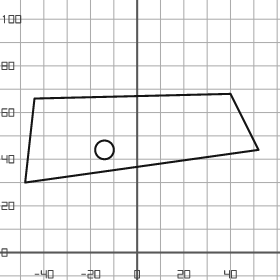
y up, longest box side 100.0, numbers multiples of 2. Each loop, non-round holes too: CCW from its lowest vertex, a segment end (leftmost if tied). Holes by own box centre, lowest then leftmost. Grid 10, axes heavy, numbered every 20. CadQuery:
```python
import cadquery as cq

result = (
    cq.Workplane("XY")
    .moveTo(-48.0, 30.0)
    .lineTo(52.0, 44.0)
    .lineTo(40.0, 68.0)
    .lineTo(-44.0, 66.0)
    .close()
    .moveTo(-14.0, 44.0)
    .circle(4.0)
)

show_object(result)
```